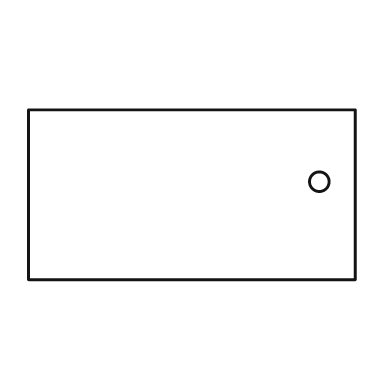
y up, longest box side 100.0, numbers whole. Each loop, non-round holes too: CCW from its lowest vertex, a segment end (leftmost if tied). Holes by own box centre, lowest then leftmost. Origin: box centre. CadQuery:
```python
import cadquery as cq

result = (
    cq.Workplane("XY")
    .moveTo(-50.0, -26.0)
    .lineTo(50.0, -26.0)
    .lineTo(50.0, 26.0)
    .lineTo(-50.0, 26.0)
    .close()
    .moveTo(39.0, 4.0)
    .circle(3.0)
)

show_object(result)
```